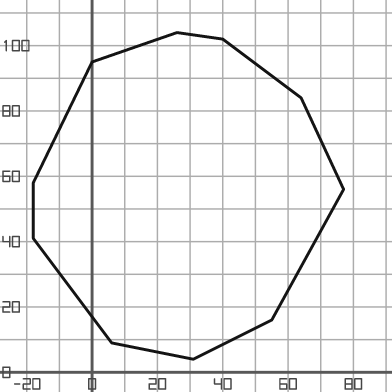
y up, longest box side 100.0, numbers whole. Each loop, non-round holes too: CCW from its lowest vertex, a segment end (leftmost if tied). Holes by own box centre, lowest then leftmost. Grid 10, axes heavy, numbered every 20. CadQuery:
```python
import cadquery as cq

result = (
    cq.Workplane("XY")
    .moveTo(31.0, 4.0)
    .lineTo(55.0, 16.0)
    .lineTo(77.0, 56.0)
    .lineTo(64.0, 84.0)
    .lineTo(40.0, 102.0)
    .lineTo(26.0, 104.0)
    .lineTo(0.0, 95.0)
    .lineTo(-18.0, 58.0)
    .lineTo(-18.0, 41.0)
    .lineTo(6.0, 9.0)
    .close()
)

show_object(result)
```